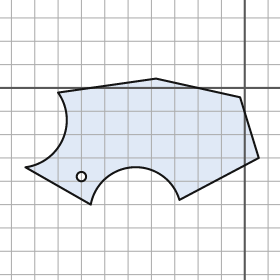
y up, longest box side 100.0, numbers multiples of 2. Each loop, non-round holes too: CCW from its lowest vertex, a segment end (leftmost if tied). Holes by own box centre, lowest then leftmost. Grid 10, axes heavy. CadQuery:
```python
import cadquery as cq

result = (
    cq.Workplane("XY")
    .moveTo(-66.0, -50.0)
    .threePointArc((-48.0, -34.0), (-28.0, -48.0))
    .lineTo(6.0, -30.0)
    .lineTo(-2.0, -4.0)
    .lineTo(-38.0, 4.0)
    .lineTo(-80.0, -2.0)
    .threePointArc((-78.0, -22.0), (-94.0, -34.0))
    .close()
    .moveTo(-70.0, -38.0)
    .circle(2.0)
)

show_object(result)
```